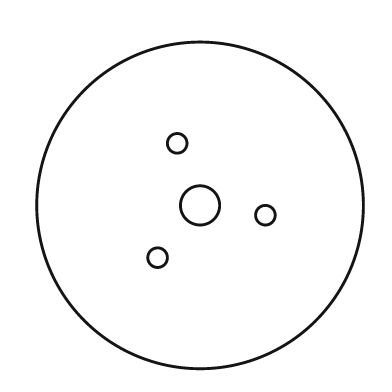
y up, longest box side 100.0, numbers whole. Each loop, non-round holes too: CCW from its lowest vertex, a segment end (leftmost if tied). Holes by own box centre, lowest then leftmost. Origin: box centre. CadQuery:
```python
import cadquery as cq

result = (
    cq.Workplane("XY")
    .moveTo(0.0, 0.0)
    .circle(50.0)
    .moveTo(-13.0, -16.0)
    .circle(3.0)
    .moveTo(20.0, -3.0)
    .circle(3.0)
    .moveTo(0.0, 0.0)
    .circle(6.0)
    .moveTo(-7.0, 19.0)
    .circle(3.0)
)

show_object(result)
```